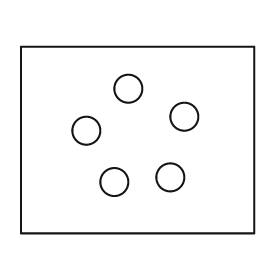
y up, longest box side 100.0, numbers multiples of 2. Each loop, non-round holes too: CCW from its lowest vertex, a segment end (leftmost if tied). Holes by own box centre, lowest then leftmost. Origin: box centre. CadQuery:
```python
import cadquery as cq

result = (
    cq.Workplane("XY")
    .moveTo(-50.0, -40.0)
    .lineTo(50.0, -40.0)
    .lineTo(50.0, 40.0)
    .lineTo(-50.0, 40.0)
    .close()
    .moveTo(-10.0, -18.0)
    .circle(6.0)
    .moveTo(14.0, -16.0)
    .circle(6.0)
    .moveTo(-22.0, 4.0)
    .circle(6.0)
    .moveTo(20.0, 10.0)
    .circle(6.0)
    .moveTo(-4.0, 22.0)
    .circle(6.0)
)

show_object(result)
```